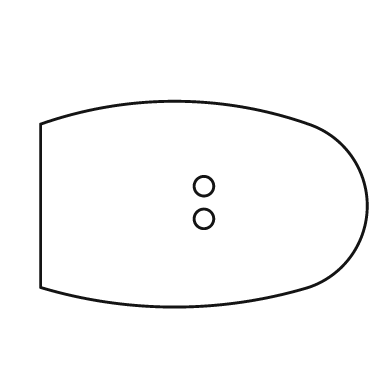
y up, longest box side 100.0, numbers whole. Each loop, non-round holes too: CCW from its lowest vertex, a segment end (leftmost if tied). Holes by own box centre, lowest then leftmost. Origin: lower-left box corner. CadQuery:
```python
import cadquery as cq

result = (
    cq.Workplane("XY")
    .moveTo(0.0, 6.0)
    .threePointArc((41.0, 0.0), (82.0, 6.0))
    .threePointArc((100.0, 31.0), (82.0, 56.0))
    .threePointArc((41.0, 63.0), (0.0, 56.0))
    .close()
    .moveTo(50.0, 27.0)
    .circle(3.0)
    .moveTo(50.0, 37.0)
    .circle(3.0)
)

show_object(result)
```